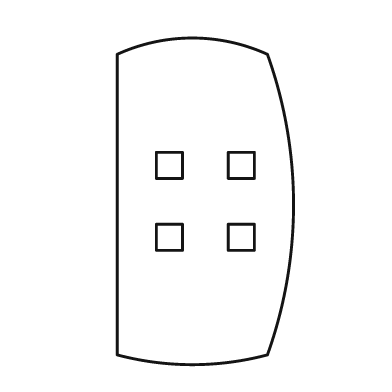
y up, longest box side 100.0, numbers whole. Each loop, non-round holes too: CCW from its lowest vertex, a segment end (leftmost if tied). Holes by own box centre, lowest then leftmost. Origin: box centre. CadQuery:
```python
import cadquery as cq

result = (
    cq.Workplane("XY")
    .moveTo(-27.0, -47.0)
    .threePointArc((-4.0, -50.0), (19.0, -47.0))
    .threePointArc((27.0, -1.0), (19.0, 45.0))
    .threePointArc((-4.0, 50.0), (-27.0, 45.0))
    .close()
    .moveTo(-15.0, -15.0)
    .lineTo(-7.0, -15.0)
    .lineTo(-7.0, -7.0)
    .lineTo(-15.0, -7.0)
    .close()
    .moveTo(7.0, -15.0)
    .lineTo(15.0, -15.0)
    .lineTo(15.0, -7.0)
    .lineTo(7.0, -7.0)
    .close()
    .moveTo(-15.0, 7.0)
    .lineTo(-7.0, 7.0)
    .lineTo(-7.0, 15.0)
    .lineTo(-15.0, 15.0)
    .close()
    .moveTo(7.0, 7.0)
    .lineTo(15.0, 7.0)
    .lineTo(15.0, 15.0)
    .lineTo(7.0, 15.0)
    .close()
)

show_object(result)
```